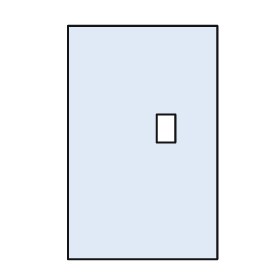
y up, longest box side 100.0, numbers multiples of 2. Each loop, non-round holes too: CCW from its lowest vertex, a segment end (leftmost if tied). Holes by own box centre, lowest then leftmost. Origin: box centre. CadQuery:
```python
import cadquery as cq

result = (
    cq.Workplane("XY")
    .moveTo(-32.0, -50.0)
    .lineTo(32.0, -50.0)
    .lineTo(32.0, 50.0)
    .lineTo(-32.0, 50.0)
    .close()
    .moveTo(6.0, 0.0)
    .lineTo(14.0, 0.0)
    .lineTo(14.0, 12.0)
    .lineTo(6.0, 12.0)
    .close()
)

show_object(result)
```